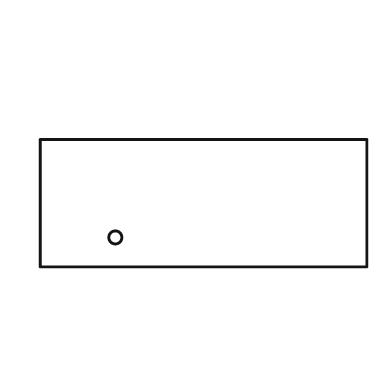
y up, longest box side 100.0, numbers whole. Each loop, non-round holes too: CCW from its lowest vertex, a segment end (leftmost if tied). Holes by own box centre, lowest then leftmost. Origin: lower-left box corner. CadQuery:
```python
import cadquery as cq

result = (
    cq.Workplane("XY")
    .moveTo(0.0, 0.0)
    .lineTo(100.0, 0.0)
    .lineTo(100.0, 39.0)
    .lineTo(0.0, 39.0)
    .close()
    .moveTo(23.0, 9.0)
    .circle(2.0)
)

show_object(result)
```